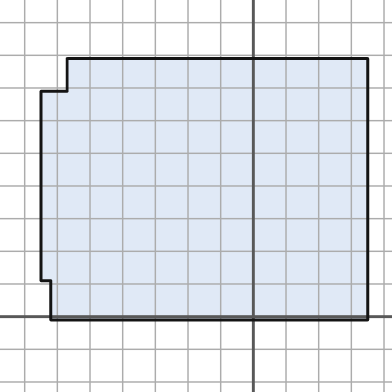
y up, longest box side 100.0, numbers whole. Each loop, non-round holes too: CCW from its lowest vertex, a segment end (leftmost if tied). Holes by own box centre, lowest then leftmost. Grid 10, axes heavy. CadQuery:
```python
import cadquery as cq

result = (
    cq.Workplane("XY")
    .moveTo(-62.0, -1.0)
    .lineTo(35.0, -1.0)
    .lineTo(35.0, 79.0)
    .lineTo(-57.0, 79.0)
    .lineTo(-57.0, 69.0)
    .lineTo(-65.0, 69.0)
    .lineTo(-65.0, 11.0)
    .lineTo(-62.0, 11.0)
    .close()
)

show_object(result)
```